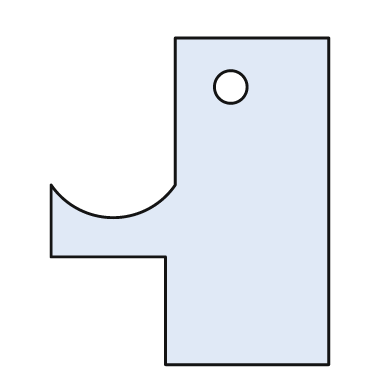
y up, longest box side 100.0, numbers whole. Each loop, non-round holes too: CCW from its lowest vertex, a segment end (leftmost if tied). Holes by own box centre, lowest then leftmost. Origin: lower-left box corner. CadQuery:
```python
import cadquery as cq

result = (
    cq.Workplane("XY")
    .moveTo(35.0, 0.0)
    .lineTo(85.0, 0.0)
    .lineTo(85.0, 100.0)
    .lineTo(38.0, 100.0)
    .lineTo(38.0, 55.0)
    .threePointArc((19.0, 45.0), (0.0, 55.0))
    .lineTo(0.0, 33.0)
    .lineTo(35.0, 33.0)
    .close()
    .moveTo(55.0, 85.0)
    .circle(5.0)
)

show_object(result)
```